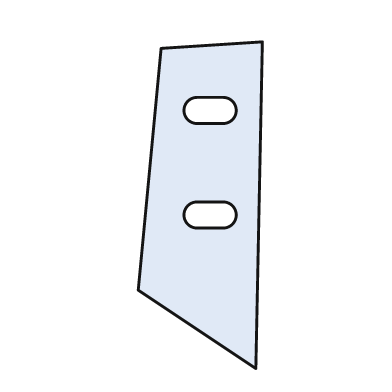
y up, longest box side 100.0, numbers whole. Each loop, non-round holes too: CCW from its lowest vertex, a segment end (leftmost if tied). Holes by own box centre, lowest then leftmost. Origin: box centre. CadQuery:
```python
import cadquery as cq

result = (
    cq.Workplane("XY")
    .moveTo(17.0, -50.0)
    .lineTo(19.0, 50.0)
    .lineTo(-12.0, 48.0)
    .lineTo(-19.0, -26.0)
    .close()
    .moveTo(-1.0, -7.0)
    .lineTo(7.0, -7.0)
    .threePointArc((11.0, -3.0), (7.0, 1.0))
    .lineTo(-1.0, 1.0)
    .threePointArc((-5.0, -3.0), (-1.0, -7.0))
    .close()
    .moveTo(-1.0, 25.0)
    .lineTo(7.0, 25.0)
    .threePointArc((11.0, 29.0), (7.0, 33.0))
    .lineTo(-1.0, 33.0)
    .threePointArc((-5.0, 29.0), (-1.0, 25.0))
    .close()
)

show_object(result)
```